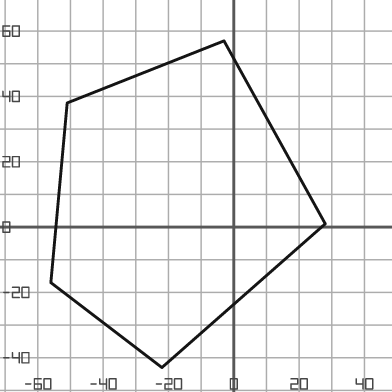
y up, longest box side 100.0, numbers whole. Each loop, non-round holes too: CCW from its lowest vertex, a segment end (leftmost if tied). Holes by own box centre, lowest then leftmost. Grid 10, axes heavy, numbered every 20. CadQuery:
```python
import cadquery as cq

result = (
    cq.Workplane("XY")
    .moveTo(-22.0, -43.0)
    .lineTo(28.0, 1.0)
    .lineTo(-3.0, 57.0)
    .lineTo(-51.0, 38.0)
    .lineTo(-56.0, -17.0)
    .close()
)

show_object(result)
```